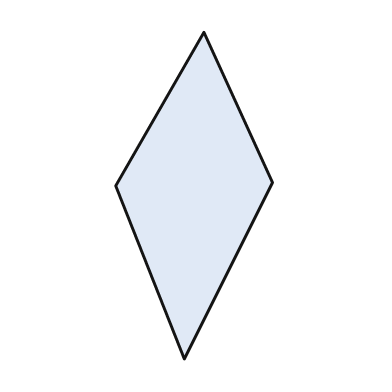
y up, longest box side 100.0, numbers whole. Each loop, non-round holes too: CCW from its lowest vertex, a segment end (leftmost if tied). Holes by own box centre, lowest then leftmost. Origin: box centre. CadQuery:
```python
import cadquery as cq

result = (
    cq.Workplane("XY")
    .moveTo(-3.0, -50.0)
    .lineTo(24.0, 4.0)
    .lineTo(3.0, 50.0)
    .lineTo(-24.0, 3.0)
    .close()
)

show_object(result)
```